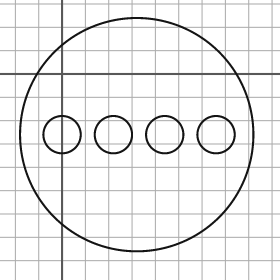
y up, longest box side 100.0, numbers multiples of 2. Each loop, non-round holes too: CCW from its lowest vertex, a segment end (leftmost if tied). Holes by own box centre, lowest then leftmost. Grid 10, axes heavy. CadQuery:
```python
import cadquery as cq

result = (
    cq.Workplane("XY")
    .moveTo(32.0, -26.0)
    .circle(50.0)
    .moveTo(0.0, -26.0)
    .circle(8.0)
    .moveTo(22.0, -26.0)
    .circle(8.0)
    .moveTo(44.0, -26.0)
    .circle(8.0)
    .moveTo(66.0, -26.0)
    .circle(8.0)
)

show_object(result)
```